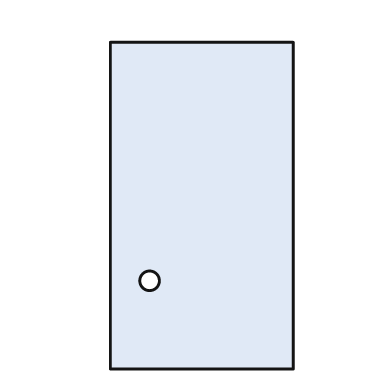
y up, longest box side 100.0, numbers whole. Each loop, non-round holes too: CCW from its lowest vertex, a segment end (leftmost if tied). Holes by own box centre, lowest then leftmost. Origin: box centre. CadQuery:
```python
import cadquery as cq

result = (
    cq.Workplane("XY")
    .moveTo(-28.0, -50.0)
    .lineTo(28.0, -50.0)
    .lineTo(28.0, 50.0)
    .lineTo(-28.0, 50.0)
    .close()
    .moveTo(-16.0, -23.0)
    .circle(3.0)
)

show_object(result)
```